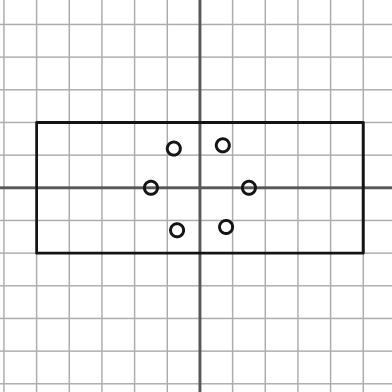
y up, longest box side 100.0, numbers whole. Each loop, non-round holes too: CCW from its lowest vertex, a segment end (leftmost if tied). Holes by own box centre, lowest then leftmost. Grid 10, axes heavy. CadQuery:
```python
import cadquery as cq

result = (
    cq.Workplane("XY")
    .moveTo(-50.0, -20.0)
    .lineTo(50.0, -20.0)
    .lineTo(50.0, 20.0)
    .lineTo(-50.0, 20.0)
    .close()
    .moveTo(-7.0, -13.0)
    .circle(2.0)
    .moveTo(8.0, -12.0)
    .circle(2.0)
    .moveTo(-15.0, 0.0)
    .circle(2.0)
    .moveTo(15.0, 0.0)
    .circle(2.0)
    .moveTo(-8.0, 12.0)
    .circle(2.0)
    .moveTo(7.0, 13.0)
    .circle(2.0)
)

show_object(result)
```